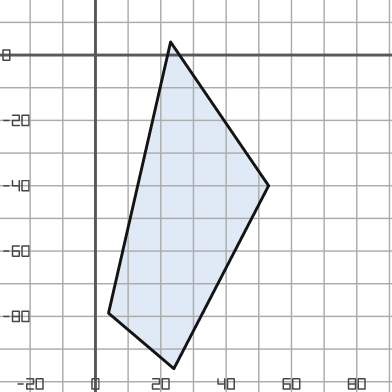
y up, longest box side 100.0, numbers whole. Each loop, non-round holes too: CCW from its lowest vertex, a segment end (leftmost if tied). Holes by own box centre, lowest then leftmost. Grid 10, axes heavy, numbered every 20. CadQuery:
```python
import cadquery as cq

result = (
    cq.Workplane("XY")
    .moveTo(24.0, -96.0)
    .lineTo(53.0, -40.0)
    .lineTo(23.0, 4.0)
    .lineTo(4.0, -79.0)
    .close()
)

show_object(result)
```